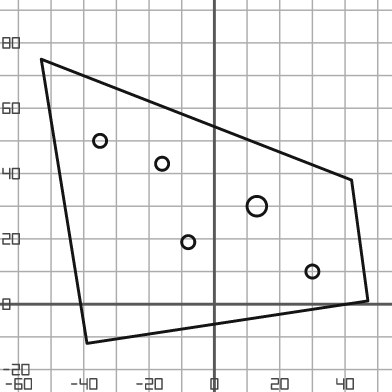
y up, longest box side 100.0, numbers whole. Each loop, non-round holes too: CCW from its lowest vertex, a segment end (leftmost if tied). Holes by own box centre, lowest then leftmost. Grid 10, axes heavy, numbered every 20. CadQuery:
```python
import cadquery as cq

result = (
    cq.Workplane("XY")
    .moveTo(-39.0, -12.0)
    .lineTo(47.0, 1.0)
    .lineTo(42.0, 38.0)
    .lineTo(-53.0, 75.0)
    .close()
    .moveTo(30.0, 10.0)
    .circle(2.0)
    .moveTo(-8.0, 19.0)
    .circle(2.0)
    .moveTo(13.0, 30.0)
    .circle(3.0)
    .moveTo(-16.0, 43.0)
    .circle(2.0)
    .moveTo(-35.0, 50.0)
    .circle(2.0)
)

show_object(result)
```